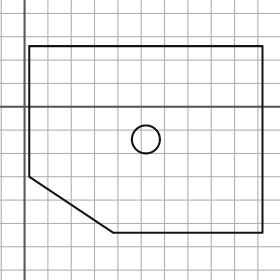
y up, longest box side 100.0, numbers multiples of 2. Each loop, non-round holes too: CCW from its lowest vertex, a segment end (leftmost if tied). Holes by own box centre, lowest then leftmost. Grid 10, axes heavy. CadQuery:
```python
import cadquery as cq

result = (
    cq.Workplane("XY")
    .moveTo(38.0, -54.0)
    .lineTo(102.0, -54.0)
    .lineTo(102.0, 26.0)
    .lineTo(2.0, 26.0)
    .lineTo(2.0, -30.0)
    .close()
    .moveTo(52.0, -14.0)
    .circle(6.0)
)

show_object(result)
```